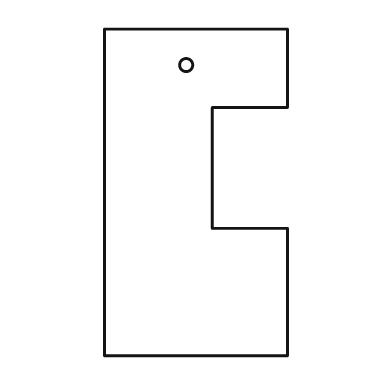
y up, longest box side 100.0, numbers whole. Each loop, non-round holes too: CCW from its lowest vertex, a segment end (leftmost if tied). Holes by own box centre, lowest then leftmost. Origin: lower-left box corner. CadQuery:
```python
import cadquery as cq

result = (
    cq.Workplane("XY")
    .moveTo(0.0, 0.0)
    .lineTo(56.0, 0.0)
    .lineTo(56.0, 39.0)
    .lineTo(33.0, 39.0)
    .lineTo(33.0, 76.0)
    .lineTo(56.0, 76.0)
    .lineTo(56.0, 100.0)
    .lineTo(0.0, 100.0)
    .close()
    .moveTo(25.0, 89.0)
    .circle(2.0)
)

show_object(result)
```